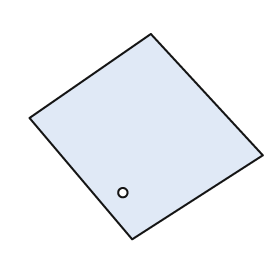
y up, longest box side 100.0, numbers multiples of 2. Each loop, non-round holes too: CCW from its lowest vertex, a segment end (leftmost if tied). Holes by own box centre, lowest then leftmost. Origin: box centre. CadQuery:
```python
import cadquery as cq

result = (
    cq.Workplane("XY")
    .moveTo(-6.0, -44.0)
    .lineTo(50.0, -8.0)
    .lineTo(2.0, 44.0)
    .lineTo(-50.0, 8.0)
    .close()
    .moveTo(-10.0, -24.0)
    .circle(2.0)
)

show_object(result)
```